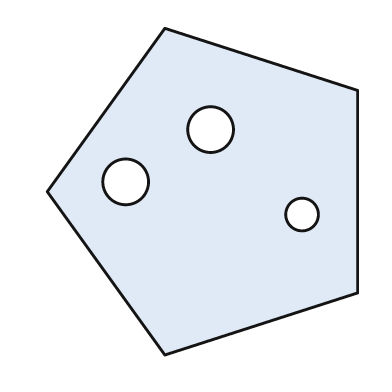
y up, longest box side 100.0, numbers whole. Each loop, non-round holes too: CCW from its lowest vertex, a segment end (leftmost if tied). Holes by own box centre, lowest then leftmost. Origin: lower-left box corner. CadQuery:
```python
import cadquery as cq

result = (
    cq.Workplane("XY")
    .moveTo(36.0, 0.0)
    .lineTo(95.0, 19.0)
    .lineTo(95.0, 81.0)
    .lineTo(36.0, 100.0)
    .lineTo(0.0, 50.0)
    .close()
    .moveTo(78.0, 43.0)
    .circle(5.0)
    .moveTo(24.0, 53.0)
    .circle(7.0)
    .moveTo(50.0, 69.0)
    .circle(7.0)
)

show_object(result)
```